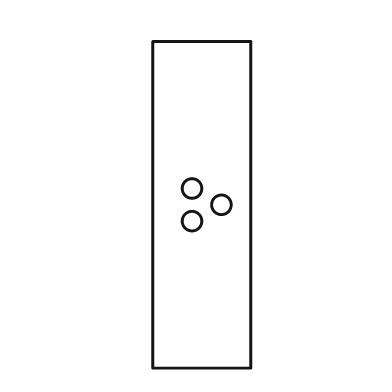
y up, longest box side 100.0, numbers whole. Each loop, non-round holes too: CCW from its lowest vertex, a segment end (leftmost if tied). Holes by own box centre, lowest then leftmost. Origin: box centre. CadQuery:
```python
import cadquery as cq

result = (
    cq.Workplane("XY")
    .moveTo(-15.0, -50.0)
    .lineTo(15.0, -50.0)
    .lineTo(15.0, 50.0)
    .lineTo(-15.0, 50.0)
    .close()
    .moveTo(-3.0, -5.0)
    .circle(3.0)
    .moveTo(6.0, 0.0)
    .circle(3.0)
    .moveTo(-3.0, 5.0)
    .circle(3.0)
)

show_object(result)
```